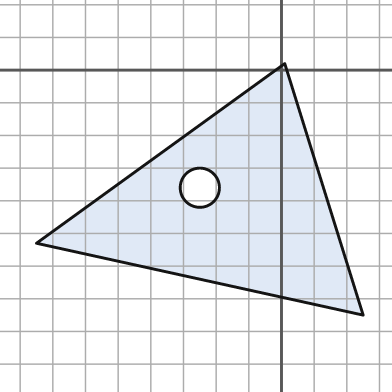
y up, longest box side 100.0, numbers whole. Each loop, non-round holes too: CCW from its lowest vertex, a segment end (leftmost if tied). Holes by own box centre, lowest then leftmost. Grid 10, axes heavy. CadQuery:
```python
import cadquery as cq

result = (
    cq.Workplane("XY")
    .moveTo(25.0, -75.0)
    .lineTo(1.0, 2.0)
    .lineTo(-75.0, -53.0)
    .close()
    .moveTo(-25.0, -36.0)
    .circle(6.0)
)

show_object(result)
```